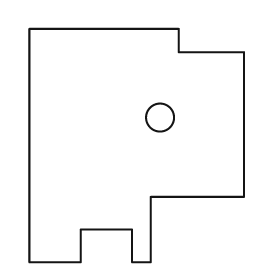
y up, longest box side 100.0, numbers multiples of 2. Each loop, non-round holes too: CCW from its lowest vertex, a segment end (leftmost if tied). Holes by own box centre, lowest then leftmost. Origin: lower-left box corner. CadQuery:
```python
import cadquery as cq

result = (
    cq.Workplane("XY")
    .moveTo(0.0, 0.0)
    .lineTo(22.0, 0.0)
    .lineTo(22.0, 14.0)
    .lineTo(44.0, 14.0)
    .lineTo(44.0, 0.0)
    .lineTo(52.0, 0.0)
    .lineTo(52.0, 28.0)
    .lineTo(92.0, 28.0)
    .lineTo(92.0, 90.0)
    .lineTo(64.0, 90.0)
    .lineTo(64.0, 100.0)
    .lineTo(0.0, 100.0)
    .close()
    .moveTo(56.0, 62.0)
    .circle(6.0)
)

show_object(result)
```